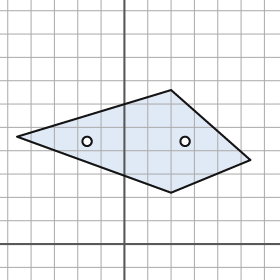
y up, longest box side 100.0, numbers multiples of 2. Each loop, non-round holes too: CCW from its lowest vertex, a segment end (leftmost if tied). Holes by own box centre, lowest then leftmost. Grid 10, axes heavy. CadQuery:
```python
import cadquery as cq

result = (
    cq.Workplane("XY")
    .moveTo(20.0, 22.0)
    .lineTo(54.0, 36.0)
    .lineTo(20.0, 66.0)
    .lineTo(-46.0, 46.0)
    .close()
    .moveTo(-16.0, 44.0)
    .circle(2.0)
    .moveTo(26.0, 44.0)
    .circle(2.0)
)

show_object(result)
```